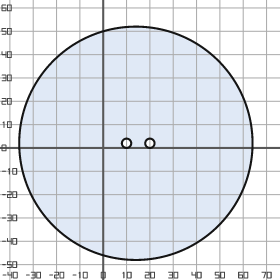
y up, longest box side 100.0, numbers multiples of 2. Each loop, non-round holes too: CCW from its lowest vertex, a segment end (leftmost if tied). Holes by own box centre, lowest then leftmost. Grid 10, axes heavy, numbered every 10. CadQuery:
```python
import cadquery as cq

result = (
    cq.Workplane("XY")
    .moveTo(14.0, 2.0)
    .circle(50.0)
    .moveTo(10.0, 2.0)
    .circle(2.0)
    .moveTo(20.0, 2.0)
    .circle(2.0)
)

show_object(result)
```